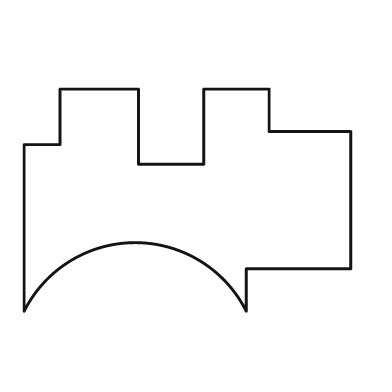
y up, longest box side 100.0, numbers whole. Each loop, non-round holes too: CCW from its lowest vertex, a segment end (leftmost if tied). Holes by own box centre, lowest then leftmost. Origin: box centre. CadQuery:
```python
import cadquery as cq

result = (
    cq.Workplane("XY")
    .moveTo(-50.0, -34.0)
    .threePointArc((-16.0, -13.0), (18.0, -34.0))
    .lineTo(18.0, -21.0)
    .lineTo(50.0, -21.0)
    .lineTo(50.0, 21.0)
    .lineTo(25.0, 21.0)
    .lineTo(25.0, 34.0)
    .lineTo(5.0, 34.0)
    .lineTo(5.0, 11.0)
    .lineTo(-15.0, 11.0)
    .lineTo(-15.0, 34.0)
    .lineTo(-39.0, 34.0)
    .lineTo(-39.0, 17.0)
    .lineTo(-50.0, 17.0)
    .close()
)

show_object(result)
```